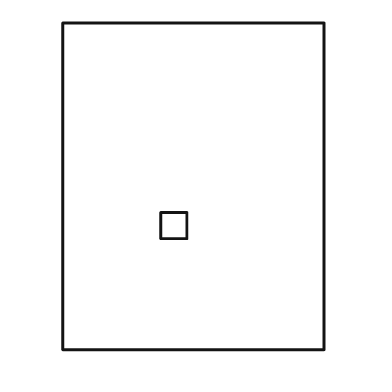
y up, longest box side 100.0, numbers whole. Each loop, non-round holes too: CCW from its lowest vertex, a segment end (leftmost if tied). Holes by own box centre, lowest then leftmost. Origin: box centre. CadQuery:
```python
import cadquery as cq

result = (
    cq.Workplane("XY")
    .moveTo(-40.0, -50.0)
    .lineTo(40.0, -50.0)
    .lineTo(40.0, 50.0)
    .lineTo(-40.0, 50.0)
    .close()
    .moveTo(-10.0, -16.0)
    .lineTo(-2.0, -16.0)
    .lineTo(-2.0, -8.0)
    .lineTo(-10.0, -8.0)
    .close()
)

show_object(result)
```